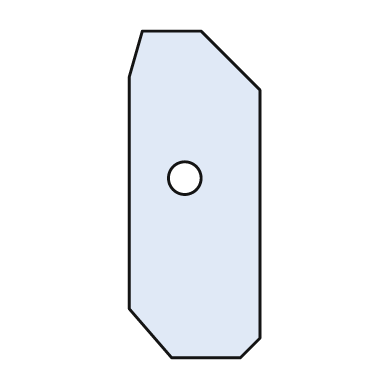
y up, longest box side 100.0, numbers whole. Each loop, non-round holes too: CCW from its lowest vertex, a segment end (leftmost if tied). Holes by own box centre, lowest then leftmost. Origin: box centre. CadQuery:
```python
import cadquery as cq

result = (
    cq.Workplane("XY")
    .moveTo(-7.0, -50.0)
    .lineTo(14.0, -50.0)
    .lineTo(20.0, -44.0)
    .lineTo(20.0, 32.0)
    .lineTo(2.0, 50.0)
    .lineTo(-16.0, 50.0)
    .lineTo(-20.0, 36.0)
    .lineTo(-20.0, -35.0)
    .close()
    .moveTo(-3.0, 5.0)
    .circle(5.0)
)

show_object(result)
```